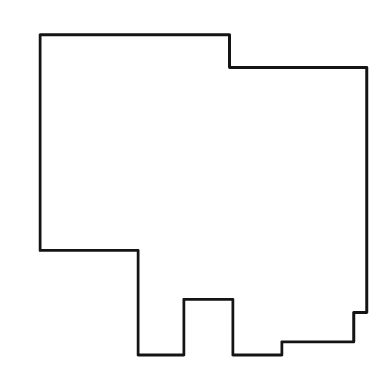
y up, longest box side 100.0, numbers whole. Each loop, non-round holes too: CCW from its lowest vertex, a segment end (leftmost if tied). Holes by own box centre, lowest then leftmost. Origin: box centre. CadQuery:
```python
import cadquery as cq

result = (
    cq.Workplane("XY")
    .moveTo(-20.0, -49.0)
    .lineTo(-6.0, -49.0)
    .lineTo(-6.0, -32.0)
    .lineTo(9.0, -32.0)
    .lineTo(9.0, -49.0)
    .lineTo(24.0, -49.0)
    .lineTo(24.0, -45.0)
    .lineTo(46.0, -45.0)
    .lineTo(46.0, -36.0)
    .lineTo(50.0, -36.0)
    .lineTo(50.0, 39.0)
    .lineTo(8.0, 39.0)
    .lineTo(8.0, 49.0)
    .lineTo(-50.0, 49.0)
    .lineTo(-50.0, -17.0)
    .lineTo(-20.0, -17.0)
    .close()
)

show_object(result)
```